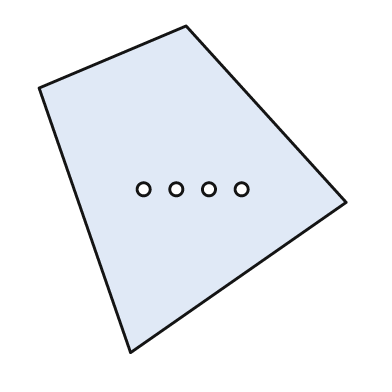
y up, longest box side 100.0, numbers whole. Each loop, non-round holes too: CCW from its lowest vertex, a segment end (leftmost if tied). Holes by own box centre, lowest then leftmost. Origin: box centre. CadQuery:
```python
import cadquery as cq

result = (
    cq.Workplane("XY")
    .moveTo(-19.0, -50.0)
    .lineTo(47.0, -4.0)
    .lineTo(-2.0, 50.0)
    .lineTo(-47.0, 31.0)
    .close()
    .moveTo(-15.0, 0.0)
    .circle(2.0)
    .moveTo(-5.0, 0.0)
    .circle(2.0)
    .moveTo(5.0, 0.0)
    .circle(2.0)
    .moveTo(15.0, 0.0)
    .circle(2.0)
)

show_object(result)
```